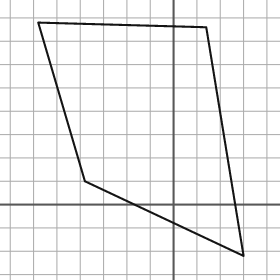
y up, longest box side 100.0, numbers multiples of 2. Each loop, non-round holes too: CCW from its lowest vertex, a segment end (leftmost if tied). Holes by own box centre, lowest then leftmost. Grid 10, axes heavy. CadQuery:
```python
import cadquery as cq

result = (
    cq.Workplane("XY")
    .moveTo(30.0, -22.0)
    .lineTo(14.0, 76.0)
    .lineTo(-58.0, 78.0)
    .lineTo(-38.0, 10.0)
    .close()
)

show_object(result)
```